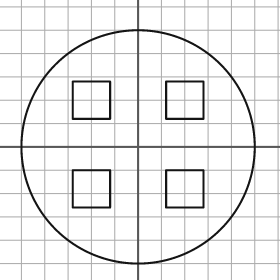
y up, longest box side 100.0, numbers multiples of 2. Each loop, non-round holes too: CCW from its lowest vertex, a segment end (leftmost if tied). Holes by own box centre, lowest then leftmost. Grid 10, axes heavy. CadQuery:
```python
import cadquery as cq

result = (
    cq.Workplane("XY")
    .moveTo(0.0, 0.0)
    .circle(50.0)
    .moveTo(-28.0, -26.0)
    .lineTo(-12.0, -26.0)
    .lineTo(-12.0, -10.0)
    .lineTo(-28.0, -10.0)
    .close()
    .moveTo(12.0, -26.0)
    .lineTo(28.0, -26.0)
    .lineTo(28.0, -10.0)
    .lineTo(12.0, -10.0)
    .close()
    .moveTo(-28.0, 12.0)
    .lineTo(-12.0, 12.0)
    .lineTo(-12.0, 28.0)
    .lineTo(-28.0, 28.0)
    .close()
    .moveTo(12.0, 12.0)
    .lineTo(28.0, 12.0)
    .lineTo(28.0, 28.0)
    .lineTo(12.0, 28.0)
    .close()
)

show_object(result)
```